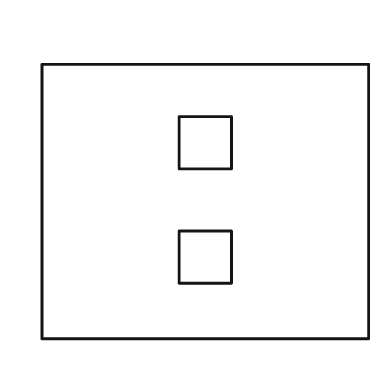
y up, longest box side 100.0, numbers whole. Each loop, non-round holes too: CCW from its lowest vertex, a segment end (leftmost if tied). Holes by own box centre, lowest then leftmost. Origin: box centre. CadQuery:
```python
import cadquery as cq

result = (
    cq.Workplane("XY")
    .moveTo(-50.0, -42.0)
    .lineTo(50.0, -42.0)
    .lineTo(50.0, 42.0)
    .lineTo(-50.0, 42.0)
    .close()
    .moveTo(-8.0, -25.0)
    .lineTo(8.0, -25.0)
    .lineTo(8.0, -9.0)
    .lineTo(-8.0, -9.0)
    .close()
    .moveTo(-8.0, 10.0)
    .lineTo(8.0, 10.0)
    .lineTo(8.0, 26.0)
    .lineTo(-8.0, 26.0)
    .close()
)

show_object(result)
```